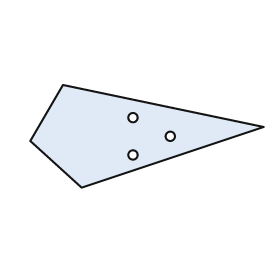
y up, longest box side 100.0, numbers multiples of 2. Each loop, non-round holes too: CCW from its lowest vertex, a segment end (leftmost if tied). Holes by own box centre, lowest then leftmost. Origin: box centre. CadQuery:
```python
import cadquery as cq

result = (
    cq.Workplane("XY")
    .moveTo(-28.0, -22.0)
    .lineTo(50.0, 4.0)
    .lineTo(-36.0, 22.0)
    .lineTo(-50.0, -2.0)
    .close()
    .moveTo(-6.0, -8.0)
    .circle(2.0)
    .moveTo(10.0, 0.0)
    .circle(2.0)
    .moveTo(-6.0, 8.0)
    .circle(2.0)
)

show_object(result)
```